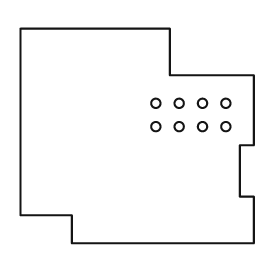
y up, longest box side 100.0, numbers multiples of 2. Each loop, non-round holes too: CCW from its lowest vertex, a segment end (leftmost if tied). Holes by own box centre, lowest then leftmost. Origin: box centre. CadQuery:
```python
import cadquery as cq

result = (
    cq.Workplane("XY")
    .moveTo(-28.0, -46.0)
    .lineTo(50.0, -46.0)
    .lineTo(50.0, -26.0)
    .lineTo(44.0, -26.0)
    .lineTo(44.0, -4.0)
    .lineTo(50.0, -4.0)
    .lineTo(50.0, 26.0)
    .lineTo(14.0, 26.0)
    .lineTo(14.0, 46.0)
    .lineTo(-50.0, 46.0)
    .lineTo(-50.0, -34.0)
    .lineTo(-28.0, -34.0)
    .close()
    .moveTo(8.0, 4.0)
    .circle(2.0)
    .moveTo(18.0, 4.0)
    .circle(2.0)
    .moveTo(28.0, 4.0)
    .circle(2.0)
    .moveTo(38.0, 4.0)
    .circle(2.0)
    .moveTo(8.0, 14.0)
    .circle(2.0)
    .moveTo(18.0, 14.0)
    .circle(2.0)
    .moveTo(28.0, 14.0)
    .circle(2.0)
    .moveTo(38.0, 14.0)
    .circle(2.0)
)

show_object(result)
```